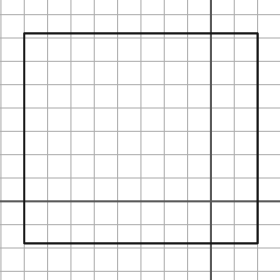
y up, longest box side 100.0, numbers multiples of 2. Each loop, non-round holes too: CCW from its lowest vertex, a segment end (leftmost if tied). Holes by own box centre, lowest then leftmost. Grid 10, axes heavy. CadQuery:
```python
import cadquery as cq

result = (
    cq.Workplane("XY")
    .moveTo(-80.0, -18.0)
    .lineTo(20.0, -18.0)
    .lineTo(20.0, 72.0)
    .lineTo(-80.0, 72.0)
    .close()
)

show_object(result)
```